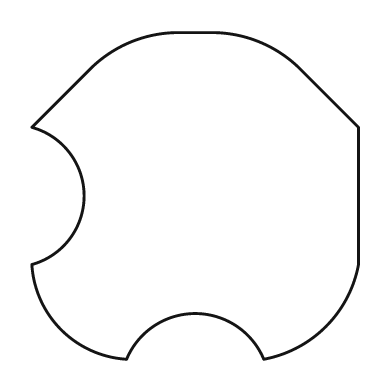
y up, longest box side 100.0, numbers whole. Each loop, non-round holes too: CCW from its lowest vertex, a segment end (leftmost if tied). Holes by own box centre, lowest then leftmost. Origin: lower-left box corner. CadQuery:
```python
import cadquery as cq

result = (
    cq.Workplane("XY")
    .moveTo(29.0, 0.0)
    .threePointArc((50.0, 14.0), (71.0, 0.0))
    .threePointArc((90.0, 10.0), (100.0, 29.0))
    .lineTo(100.0, 71.0)
    .lineTo(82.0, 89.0)
    .threePointArc((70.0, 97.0), (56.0, 100.0))
    .lineTo(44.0, 100.0)
    .threePointArc((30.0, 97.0), (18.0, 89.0))
    .lineTo(0.0, 71.0)
    .threePointArc((16.0, 50.0), (0.0, 29.0))
    .threePointArc((9.0, 9.0), (29.0, 0.0))
    .close()
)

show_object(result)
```